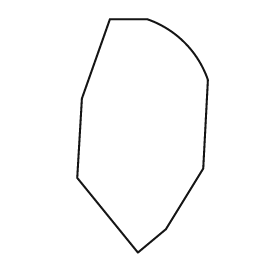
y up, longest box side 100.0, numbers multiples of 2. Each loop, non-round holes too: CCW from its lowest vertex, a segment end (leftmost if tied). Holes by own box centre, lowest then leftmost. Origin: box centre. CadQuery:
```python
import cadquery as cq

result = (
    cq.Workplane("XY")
    .moveTo(-2.0, -50.0)
    .lineTo(10.0, -40.0)
    .lineTo(26.0, -14.0)
    .lineTo(28.0, 24.0)
    .threePointArc((18.0, 40.0), (2.0, 50.0))
    .lineTo(-14.0, 50.0)
    .lineTo(-26.0, 16.0)
    .lineTo(-28.0, -18.0)
    .close()
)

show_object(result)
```